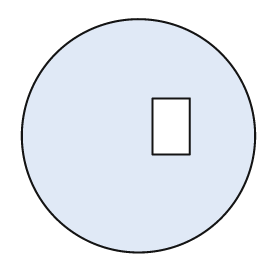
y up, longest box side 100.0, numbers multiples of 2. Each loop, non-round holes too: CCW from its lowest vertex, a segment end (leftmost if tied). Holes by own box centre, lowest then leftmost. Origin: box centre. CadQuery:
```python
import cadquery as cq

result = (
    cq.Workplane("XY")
    .moveTo(0.0, 0.0)
    .circle(50.0)
    .moveTo(6.0, -8.0)
    .lineTo(22.0, -8.0)
    .lineTo(22.0, 16.0)
    .lineTo(6.0, 16.0)
    .close()
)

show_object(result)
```